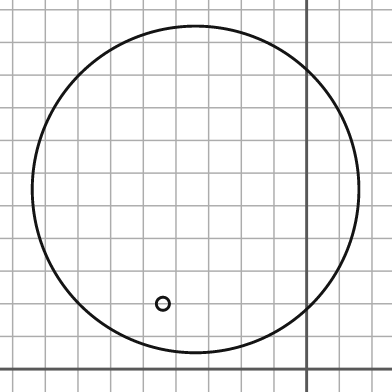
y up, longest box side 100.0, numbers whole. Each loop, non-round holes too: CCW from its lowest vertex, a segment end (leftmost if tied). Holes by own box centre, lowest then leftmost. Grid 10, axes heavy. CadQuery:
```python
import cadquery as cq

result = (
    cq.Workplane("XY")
    .moveTo(-34.0, 55.0)
    .circle(50.0)
    .moveTo(-44.0, 20.0)
    .circle(2.0)
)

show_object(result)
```